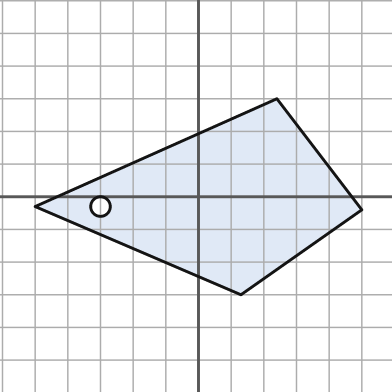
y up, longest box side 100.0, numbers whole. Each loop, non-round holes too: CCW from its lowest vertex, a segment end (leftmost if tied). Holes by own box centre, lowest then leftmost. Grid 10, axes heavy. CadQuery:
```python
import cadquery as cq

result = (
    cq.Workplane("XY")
    .moveTo(13.0, -30.0)
    .lineTo(50.0, -4.0)
    .lineTo(24.0, 30.0)
    .lineTo(-50.0, -3.0)
    .close()
    .moveTo(-30.0, -3.0)
    .circle(3.0)
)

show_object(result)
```